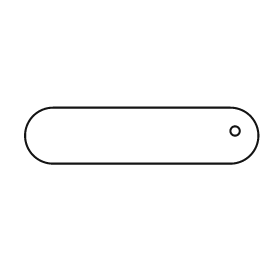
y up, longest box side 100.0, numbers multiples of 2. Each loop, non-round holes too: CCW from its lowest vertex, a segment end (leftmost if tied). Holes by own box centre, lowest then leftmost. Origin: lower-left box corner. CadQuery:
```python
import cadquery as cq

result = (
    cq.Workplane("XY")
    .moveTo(12.0, 0.0)
    .lineTo(88.0, 0.0)
    .threePointArc((100.0, 12.0), (88.0, 24.0))
    .lineTo(12.0, 24.0)
    .threePointArc((0.0, 12.0), (12.0, 0.0))
    .close()
    .moveTo(90.0, 14.0)
    .circle(2.0)
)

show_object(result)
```